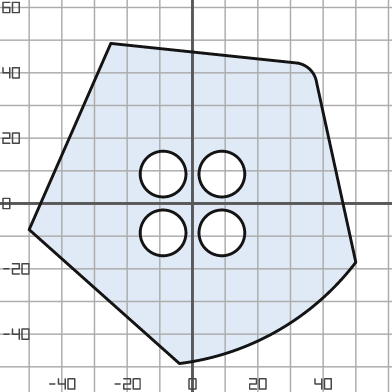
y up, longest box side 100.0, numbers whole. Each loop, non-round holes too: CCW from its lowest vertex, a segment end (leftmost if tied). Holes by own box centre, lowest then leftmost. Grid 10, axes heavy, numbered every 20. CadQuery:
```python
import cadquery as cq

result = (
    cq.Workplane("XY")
    .moveTo(-4.0, -49.0)
    .threePointArc((26.0, -39.0), (50.0, -18.0))
    .lineTo(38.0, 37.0)
    .threePointArc((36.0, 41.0), (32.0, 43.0))
    .lineTo(-25.0, 49.0)
    .lineTo(-50.0, -8.0)
    .close()
    .moveTo(-9.0, -9.0)
    .circle(7.0)
    .moveTo(9.0, -9.0)
    .circle(7.0)
    .moveTo(-9.0, 9.0)
    .circle(7.0)
    .moveTo(9.0, 9.0)
    .circle(7.0)
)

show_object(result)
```